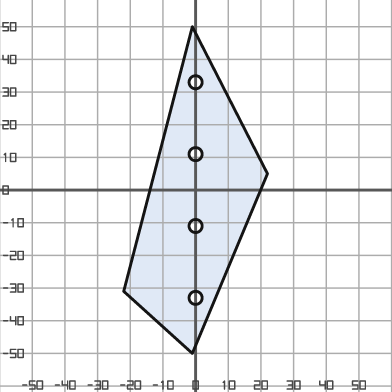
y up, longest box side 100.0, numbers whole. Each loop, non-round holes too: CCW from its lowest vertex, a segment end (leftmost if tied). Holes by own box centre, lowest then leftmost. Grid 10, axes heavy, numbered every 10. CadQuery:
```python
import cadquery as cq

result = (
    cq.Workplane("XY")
    .moveTo(-1.0, -50.0)
    .lineTo(22.0, 5.0)
    .lineTo(-1.0, 50.0)
    .lineTo(-22.0, -31.0)
    .close()
    .moveTo(0.0, -33.0)
    .circle(2.0)
    .moveTo(0.0, -11.0)
    .circle(2.0)
    .moveTo(0.0, 11.0)
    .circle(2.0)
    .moveTo(0.0, 33.0)
    .circle(2.0)
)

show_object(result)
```